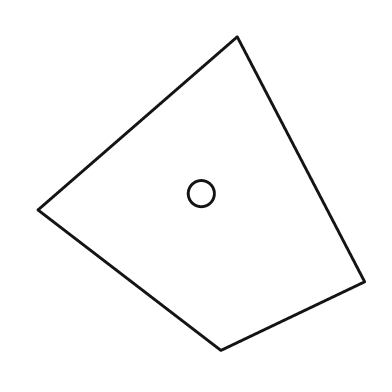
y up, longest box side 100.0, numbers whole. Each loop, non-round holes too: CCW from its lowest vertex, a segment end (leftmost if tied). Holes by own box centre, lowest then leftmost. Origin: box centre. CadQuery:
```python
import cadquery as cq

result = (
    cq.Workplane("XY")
    .moveTo(6.0, -48.0)
    .lineTo(50.0, -27.0)
    .lineTo(11.0, 48.0)
    .lineTo(-50.0, -5.0)
    .close()
    .moveTo(0.0, 0.0)
    .circle(4.0)
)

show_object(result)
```